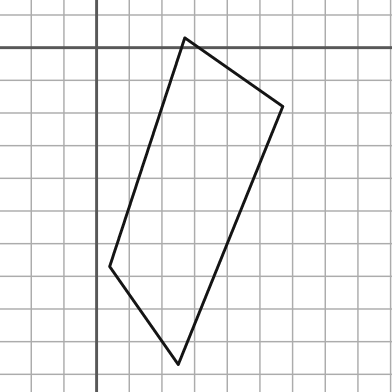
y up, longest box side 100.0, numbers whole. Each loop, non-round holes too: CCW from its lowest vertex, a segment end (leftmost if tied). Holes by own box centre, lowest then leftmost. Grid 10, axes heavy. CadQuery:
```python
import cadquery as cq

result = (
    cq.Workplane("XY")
    .moveTo(25.0, -97.0)
    .lineTo(57.0, -18.0)
    .lineTo(27.0, 3.0)
    .lineTo(4.0, -67.0)
    .close()
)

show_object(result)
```